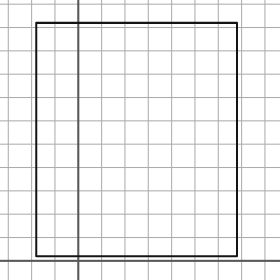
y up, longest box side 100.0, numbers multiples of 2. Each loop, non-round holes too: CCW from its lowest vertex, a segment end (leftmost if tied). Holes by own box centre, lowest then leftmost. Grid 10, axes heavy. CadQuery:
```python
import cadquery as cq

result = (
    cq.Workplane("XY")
    .moveTo(-18.0, 2.0)
    .lineTo(68.0, 2.0)
    .lineTo(68.0, 102.0)
    .lineTo(-18.0, 102.0)
    .close()
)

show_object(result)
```